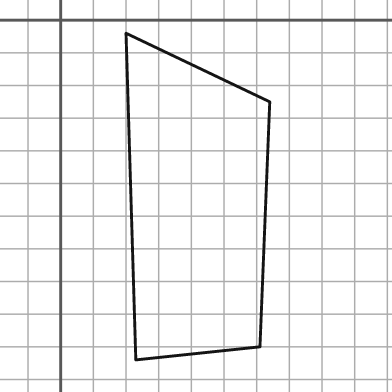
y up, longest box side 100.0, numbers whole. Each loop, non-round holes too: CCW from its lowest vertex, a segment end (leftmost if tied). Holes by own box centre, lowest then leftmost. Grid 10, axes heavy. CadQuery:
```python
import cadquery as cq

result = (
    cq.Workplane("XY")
    .moveTo(23.0, -104.0)
    .lineTo(61.0, -100.0)
    .lineTo(64.0, -25.0)
    .lineTo(20.0, -4.0)
    .close()
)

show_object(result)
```